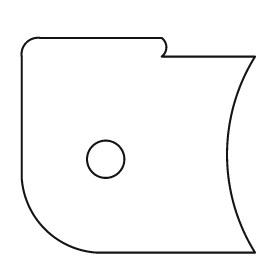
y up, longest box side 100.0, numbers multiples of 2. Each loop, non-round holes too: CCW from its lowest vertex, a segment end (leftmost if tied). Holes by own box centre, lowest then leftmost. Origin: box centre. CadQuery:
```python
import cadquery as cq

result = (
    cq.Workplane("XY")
    .moveTo(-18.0, -46.0)
    .lineTo(50.0, -46.0)
    .threePointArc((38.0, -4.0), (50.0, 38.0))
    .lineTo(10.0, 38.0)
    .threePointArc((12.0, 42.0), (10.0, 46.0))
    .lineTo(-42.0, 46.0)
    .threePointArc((-48.0, 44.0), (-50.0, 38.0))
    .lineTo(-50.0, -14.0)
    .threePointArc((-40.0, -36.0), (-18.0, -46.0))
    .close()
    .moveTo(-14.0, -6.0)
    .circle(8.0)
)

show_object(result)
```